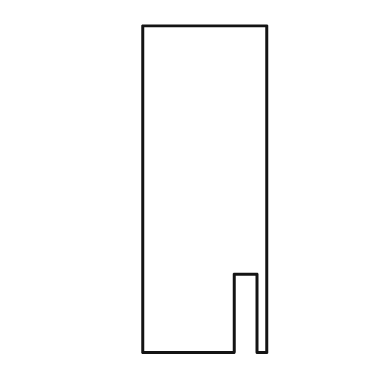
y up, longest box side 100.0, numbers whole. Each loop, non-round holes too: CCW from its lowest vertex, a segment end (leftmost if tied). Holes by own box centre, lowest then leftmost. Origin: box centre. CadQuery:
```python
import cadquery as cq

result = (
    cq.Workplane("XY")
    .moveTo(-19.0, -50.0)
    .lineTo(9.0, -50.0)
    .lineTo(9.0, -26.0)
    .lineTo(16.0, -26.0)
    .lineTo(16.0, -50.0)
    .lineTo(19.0, -50.0)
    .lineTo(19.0, 50.0)
    .lineTo(-19.0, 50.0)
    .close()
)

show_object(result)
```